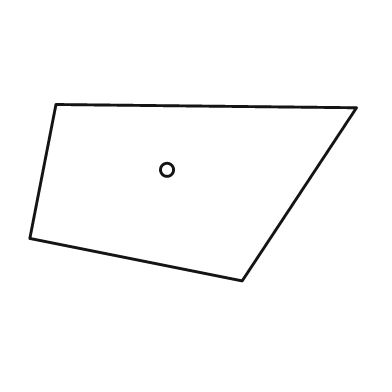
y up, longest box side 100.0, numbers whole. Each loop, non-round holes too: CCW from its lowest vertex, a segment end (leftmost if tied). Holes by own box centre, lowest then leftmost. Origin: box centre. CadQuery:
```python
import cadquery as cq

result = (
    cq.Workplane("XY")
    .moveTo(15.0, -27.0)
    .lineTo(50.0, 26.0)
    .lineTo(-42.0, 27.0)
    .lineTo(-50.0, -14.0)
    .close()
    .moveTo(-8.0, 7.0)
    .circle(2.0)
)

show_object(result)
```